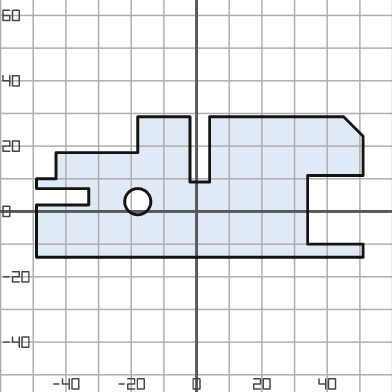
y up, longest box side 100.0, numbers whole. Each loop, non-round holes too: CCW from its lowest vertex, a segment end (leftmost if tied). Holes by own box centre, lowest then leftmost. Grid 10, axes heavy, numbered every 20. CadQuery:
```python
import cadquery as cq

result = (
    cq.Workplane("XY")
    .moveTo(-49.0, -14.0)
    .lineTo(51.0, -14.0)
    .lineTo(51.0, -10.0)
    .lineTo(34.0, -10.0)
    .lineTo(34.0, 11.0)
    .lineTo(51.0, 11.0)
    .lineTo(51.0, 23.0)
    .lineTo(45.0, 29.0)
    .lineTo(4.0, 29.0)
    .lineTo(4.0, 9.0)
    .lineTo(-2.0, 9.0)
    .lineTo(-2.0, 29.0)
    .lineTo(-18.0, 29.0)
    .lineTo(-18.0, 18.0)
    .lineTo(-43.0, 18.0)
    .lineTo(-43.0, 10.0)
    .lineTo(-49.0, 10.0)
    .lineTo(-49.0, 7.0)
    .lineTo(-33.0, 7.0)
    .lineTo(-33.0, 2.0)
    .lineTo(-49.0, 2.0)
    .close()
    .moveTo(-18.0, 3.0)
    .circle(4.0)
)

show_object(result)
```